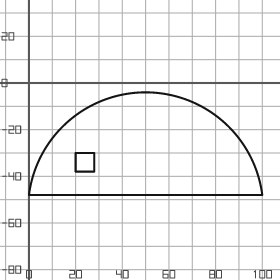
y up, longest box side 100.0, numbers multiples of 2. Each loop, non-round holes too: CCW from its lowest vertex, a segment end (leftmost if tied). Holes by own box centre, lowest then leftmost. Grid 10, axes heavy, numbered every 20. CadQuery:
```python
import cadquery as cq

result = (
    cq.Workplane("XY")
    .moveTo(0.0, -48.0)
    .lineTo(100.0, -48.0)
    .threePointArc((50.0, -4.0), (0.0, -48.0))
    .close()
    .moveTo(20.0, -38.0)
    .lineTo(28.0, -38.0)
    .lineTo(28.0, -30.0)
    .lineTo(20.0, -30.0)
    .close()
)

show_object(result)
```